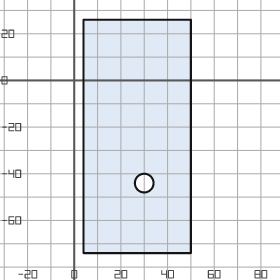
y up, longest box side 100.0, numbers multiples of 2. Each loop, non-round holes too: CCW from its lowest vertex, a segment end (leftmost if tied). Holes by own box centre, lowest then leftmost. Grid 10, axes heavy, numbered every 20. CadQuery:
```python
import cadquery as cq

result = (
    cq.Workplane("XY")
    .moveTo(4.0, -74.0)
    .lineTo(50.0, -74.0)
    .lineTo(50.0, 26.0)
    .lineTo(4.0, 26.0)
    .close()
    .moveTo(30.0, -44.0)
    .circle(4.0)
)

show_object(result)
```